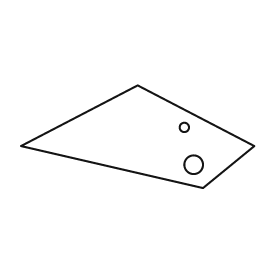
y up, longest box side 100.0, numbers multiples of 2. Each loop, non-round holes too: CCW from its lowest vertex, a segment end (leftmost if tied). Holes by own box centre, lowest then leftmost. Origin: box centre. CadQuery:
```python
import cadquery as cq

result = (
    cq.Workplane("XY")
    .moveTo(28.0, -22.0)
    .lineTo(50.0, -4.0)
    .lineTo(0.0, 22.0)
    .lineTo(-50.0, -4.0)
    .close()
    .moveTo(24.0, -12.0)
    .circle(4.0)
    .moveTo(20.0, 4.0)
    .circle(2.0)
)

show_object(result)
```